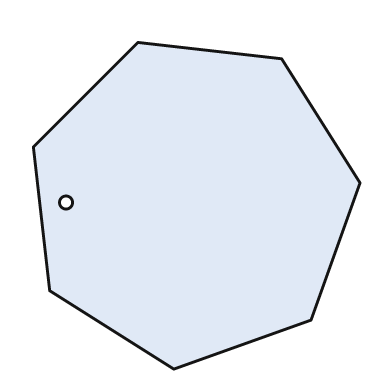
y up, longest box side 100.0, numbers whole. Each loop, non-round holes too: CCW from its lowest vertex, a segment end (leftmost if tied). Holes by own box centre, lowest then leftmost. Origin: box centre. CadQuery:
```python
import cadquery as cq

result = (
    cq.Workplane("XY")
    .moveTo(-7.0, -50.0)
    .lineTo(35.0, -35.0)
    .lineTo(50.0, 7.0)
    .lineTo(26.0, 45.0)
    .lineTo(-18.0, 50.0)
    .lineTo(-50.0, 18.0)
    .lineTo(-45.0, -26.0)
    .close()
    .moveTo(-40.0, 1.0)
    .circle(2.0)
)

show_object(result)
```